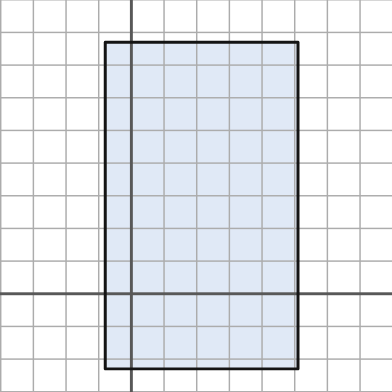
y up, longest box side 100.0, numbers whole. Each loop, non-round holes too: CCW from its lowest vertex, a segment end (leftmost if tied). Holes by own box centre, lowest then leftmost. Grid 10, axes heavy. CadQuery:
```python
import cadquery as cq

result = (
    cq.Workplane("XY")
    .moveTo(-8.0, -23.0)
    .lineTo(51.0, -23.0)
    .lineTo(51.0, 77.0)
    .lineTo(-8.0, 77.0)
    .close()
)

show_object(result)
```